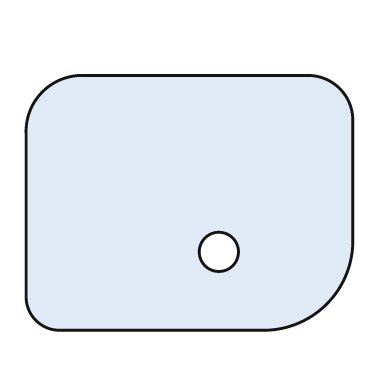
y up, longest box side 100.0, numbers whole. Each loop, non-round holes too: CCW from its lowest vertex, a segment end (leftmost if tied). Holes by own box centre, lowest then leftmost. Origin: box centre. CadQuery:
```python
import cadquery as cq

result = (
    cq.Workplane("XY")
    .moveTo(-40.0, -39.0)
    .lineTo(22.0, -39.0)
    .threePointArc((42.0, -31.0), (50.0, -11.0))
    .lineTo(50.0, 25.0)
    .threePointArc((46.0, 35.0), (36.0, 39.0))
    .lineTo(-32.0, 39.0)
    .threePointArc((-45.0, 34.0), (-50.0, 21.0))
    .lineTo(-50.0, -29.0)
    .threePointArc((-47.0, -36.0), (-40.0, -39.0))
    .close()
    .moveTo(9.0, -15.0)
    .circle(6.0)
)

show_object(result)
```